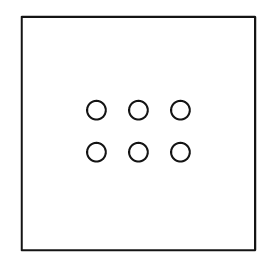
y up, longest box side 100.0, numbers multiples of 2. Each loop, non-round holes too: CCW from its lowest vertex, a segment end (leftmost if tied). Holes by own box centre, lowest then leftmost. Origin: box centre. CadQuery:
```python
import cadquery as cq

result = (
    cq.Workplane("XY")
    .moveTo(-50.0, -50.0)
    .lineTo(50.0, -50.0)
    .lineTo(50.0, 50.0)
    .lineTo(-50.0, 50.0)
    .close()
    .moveTo(-18.0, -8.0)
    .circle(4.0)
    .moveTo(0.0, -8.0)
    .circle(4.0)
    .moveTo(18.0, -8.0)
    .circle(4.0)
    .moveTo(-18.0, 10.0)
    .circle(4.0)
    .moveTo(0.0, 10.0)
    .circle(4.0)
    .moveTo(18.0, 10.0)
    .circle(4.0)
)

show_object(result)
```